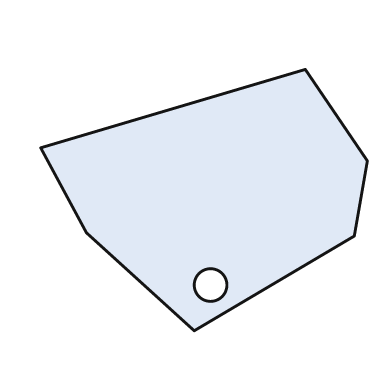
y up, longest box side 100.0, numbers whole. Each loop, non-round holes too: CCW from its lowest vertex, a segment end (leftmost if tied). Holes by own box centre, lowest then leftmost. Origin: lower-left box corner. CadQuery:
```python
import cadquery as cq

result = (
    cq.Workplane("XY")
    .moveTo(47.0, 0.0)
    .lineTo(96.0, 29.0)
    .lineTo(100.0, 52.0)
    .lineTo(81.0, 80.0)
    .lineTo(0.0, 56.0)
    .lineTo(14.0, 30.0)
    .close()
    .moveTo(52.0, 14.0)
    .circle(5.0)
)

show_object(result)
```